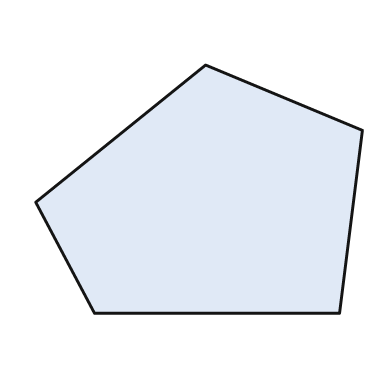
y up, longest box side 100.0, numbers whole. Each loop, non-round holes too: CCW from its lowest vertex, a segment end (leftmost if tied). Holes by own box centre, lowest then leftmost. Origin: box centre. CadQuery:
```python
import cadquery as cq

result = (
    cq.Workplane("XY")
    .moveTo(-32.0, -38.0)
    .lineTo(43.0, -38.0)
    .lineTo(50.0, 18.0)
    .lineTo(2.0, 38.0)
    .lineTo(-50.0, -4.0)
    .close()
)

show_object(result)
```